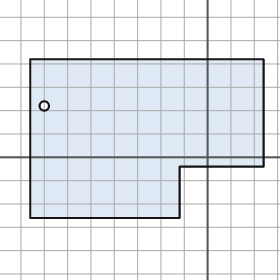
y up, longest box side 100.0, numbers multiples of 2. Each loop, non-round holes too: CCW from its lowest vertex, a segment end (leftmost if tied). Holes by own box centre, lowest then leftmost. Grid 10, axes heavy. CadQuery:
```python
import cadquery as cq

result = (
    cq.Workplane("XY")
    .moveTo(-76.0, -26.0)
    .lineTo(-12.0, -26.0)
    .lineTo(-12.0, -4.0)
    .lineTo(24.0, -4.0)
    .lineTo(24.0, 42.0)
    .lineTo(-76.0, 42.0)
    .close()
    .moveTo(-70.0, 22.0)
    .circle(2.0)
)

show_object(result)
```